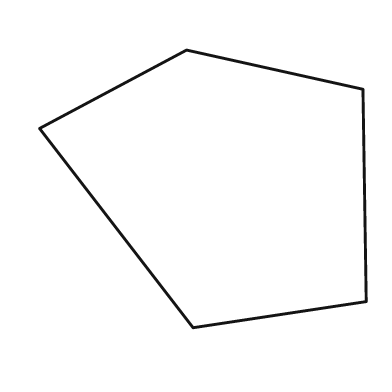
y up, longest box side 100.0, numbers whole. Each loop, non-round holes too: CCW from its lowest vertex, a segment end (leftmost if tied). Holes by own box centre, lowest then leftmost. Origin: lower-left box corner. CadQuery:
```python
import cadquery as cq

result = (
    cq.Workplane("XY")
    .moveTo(47.0, 0.0)
    .lineTo(100.0, 8.0)
    .lineTo(99.0, 73.0)
    .lineTo(45.0, 85.0)
    .lineTo(0.0, 61.0)
    .close()
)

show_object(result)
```